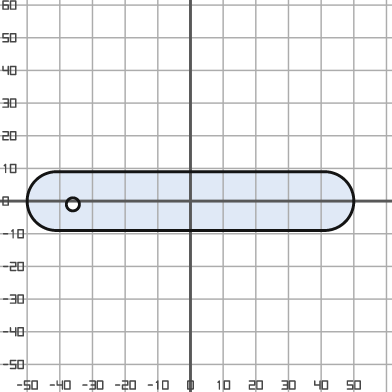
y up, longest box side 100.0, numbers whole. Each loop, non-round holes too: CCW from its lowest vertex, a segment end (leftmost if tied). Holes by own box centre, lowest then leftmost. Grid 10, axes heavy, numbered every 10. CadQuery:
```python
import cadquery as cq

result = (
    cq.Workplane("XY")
    .moveTo(-41.0, -9.0)
    .lineTo(41.0, -9.0)
    .threePointArc((50.0, 0.0), (41.0, 9.0))
    .lineTo(-41.0, 9.0)
    .threePointArc((-50.0, 0.0), (-41.0, -9.0))
    .close()
    .moveTo(-36.0, -1.0)
    .circle(2.0)
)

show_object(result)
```